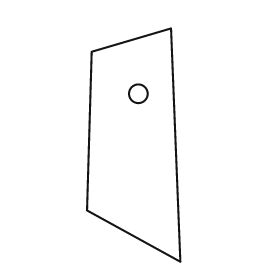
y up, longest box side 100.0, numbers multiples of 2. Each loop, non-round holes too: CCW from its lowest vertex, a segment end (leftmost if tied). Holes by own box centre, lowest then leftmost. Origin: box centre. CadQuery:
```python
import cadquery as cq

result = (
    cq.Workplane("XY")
    .moveTo(20.0, -50.0)
    .lineTo(16.0, 50.0)
    .lineTo(-18.0, 40.0)
    .lineTo(-20.0, -28.0)
    .close()
    .moveTo(2.0, 22.0)
    .circle(4.0)
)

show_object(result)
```